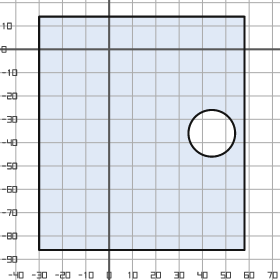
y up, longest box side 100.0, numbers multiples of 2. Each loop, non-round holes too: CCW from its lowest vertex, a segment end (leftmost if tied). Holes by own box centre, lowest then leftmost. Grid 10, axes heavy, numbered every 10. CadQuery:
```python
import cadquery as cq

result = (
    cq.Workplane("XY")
    .moveTo(-30.0, -86.0)
    .lineTo(58.0, -86.0)
    .lineTo(58.0, 14.0)
    .lineTo(-30.0, 14.0)
    .close()
    .moveTo(44.0, -36.0)
    .circle(10.0)
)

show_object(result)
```